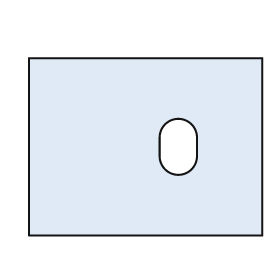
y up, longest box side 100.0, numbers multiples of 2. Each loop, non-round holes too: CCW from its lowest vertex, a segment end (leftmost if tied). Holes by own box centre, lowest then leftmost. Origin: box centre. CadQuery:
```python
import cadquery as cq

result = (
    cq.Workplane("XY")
    .moveTo(-50.0, -38.0)
    .lineTo(50.0, -38.0)
    .lineTo(50.0, 38.0)
    .lineTo(-50.0, 38.0)
    .close()
    .moveTo(6.0, -4.0)
    .threePointArc((14.0, -12.0), (22.0, -4.0))
    .lineTo(22.0, 4.0)
    .threePointArc((14.0, 12.0), (6.0, 4.0))
    .close()
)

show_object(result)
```